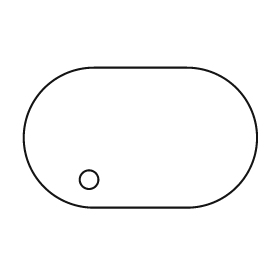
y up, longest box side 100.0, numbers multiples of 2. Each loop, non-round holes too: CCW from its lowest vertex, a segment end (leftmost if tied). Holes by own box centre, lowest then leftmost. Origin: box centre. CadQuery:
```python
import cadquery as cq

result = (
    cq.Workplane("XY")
    .moveTo(-20.0, -30.0)
    .lineTo(20.0, -30.0)
    .threePointArc((50.0, 0.0), (20.0, 30.0))
    .lineTo(-20.0, 30.0)
    .threePointArc((-50.0, 0.0), (-20.0, -30.0))
    .close()
    .moveTo(-22.0, -18.0)
    .circle(4.0)
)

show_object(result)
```